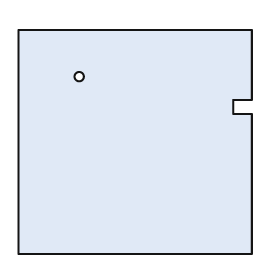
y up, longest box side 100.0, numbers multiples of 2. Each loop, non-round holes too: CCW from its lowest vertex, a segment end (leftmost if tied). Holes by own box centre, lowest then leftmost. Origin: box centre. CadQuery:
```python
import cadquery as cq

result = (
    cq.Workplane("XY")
    .moveTo(-50.0, -48.0)
    .lineTo(50.0, -48.0)
    .lineTo(50.0, 12.0)
    .lineTo(42.0, 12.0)
    .lineTo(42.0, 18.0)
    .lineTo(50.0, 18.0)
    .lineTo(50.0, 48.0)
    .lineTo(-50.0, 48.0)
    .close()
    .moveTo(-24.0, 28.0)
    .circle(2.0)
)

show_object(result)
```